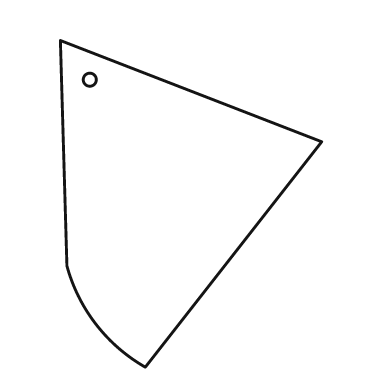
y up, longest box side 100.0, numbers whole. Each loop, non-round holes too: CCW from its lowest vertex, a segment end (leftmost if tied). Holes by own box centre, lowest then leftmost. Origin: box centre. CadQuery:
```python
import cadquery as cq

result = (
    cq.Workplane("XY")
    .moveTo(-14.0, -50.0)
    .lineTo(40.0, 19.0)
    .lineTo(-40.0, 50.0)
    .lineTo(-38.0, -19.0)
    .threePointArc((-29.0, -37.0), (-14.0, -50.0))
    .close()
    .moveTo(-31.0, 38.0)
    .circle(2.0)
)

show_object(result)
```